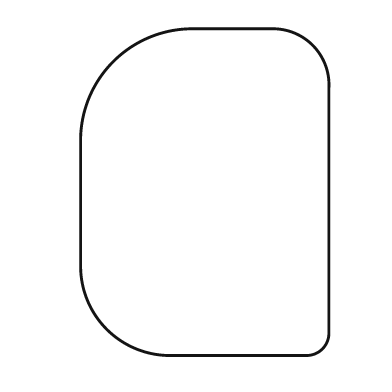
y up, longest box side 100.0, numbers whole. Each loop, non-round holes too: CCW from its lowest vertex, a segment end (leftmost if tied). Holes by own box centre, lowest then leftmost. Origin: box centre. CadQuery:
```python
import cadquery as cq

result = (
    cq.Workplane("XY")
    .moveTo(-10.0, -50.0)
    .lineTo(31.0, -50.0)
    .threePointArc((36.0, -48.0), (38.0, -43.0))
    .lineTo(38.0, 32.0)
    .threePointArc((33.0, 45.0), (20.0, 50.0))
    .lineTo(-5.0, 50.0)
    .threePointArc((-28.0, 40.0), (-38.0, 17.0))
    .lineTo(-38.0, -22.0)
    .threePointArc((-30.0, -42.0), (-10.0, -50.0))
    .close()
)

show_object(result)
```